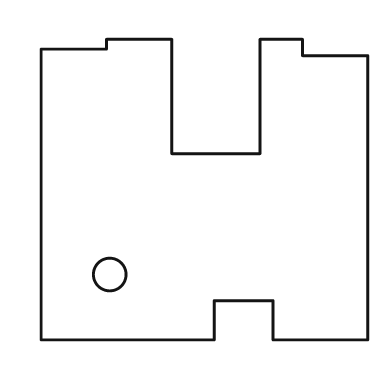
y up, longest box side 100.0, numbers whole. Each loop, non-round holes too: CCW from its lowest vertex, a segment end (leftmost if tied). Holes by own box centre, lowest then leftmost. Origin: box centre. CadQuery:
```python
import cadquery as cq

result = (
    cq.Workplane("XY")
    .moveTo(-50.0, -46.0)
    .lineTo(3.0, -46.0)
    .lineTo(3.0, -34.0)
    .lineTo(21.0, -34.0)
    .lineTo(21.0, -46.0)
    .lineTo(50.0, -46.0)
    .lineTo(50.0, 41.0)
    .lineTo(30.0, 41.0)
    .lineTo(30.0, 46.0)
    .lineTo(17.0, 46.0)
    .lineTo(17.0, 11.0)
    .lineTo(-10.0, 11.0)
    .lineTo(-10.0, 46.0)
    .lineTo(-30.0, 46.0)
    .lineTo(-30.0, 43.0)
    .lineTo(-50.0, 43.0)
    .close()
    .moveTo(-29.0, -26.0)
    .circle(5.0)
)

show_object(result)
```